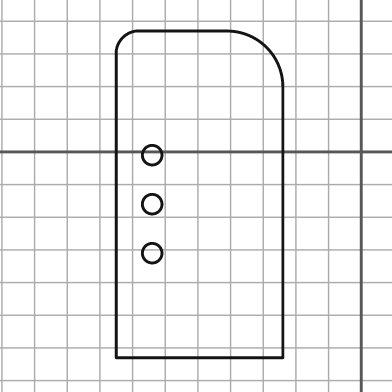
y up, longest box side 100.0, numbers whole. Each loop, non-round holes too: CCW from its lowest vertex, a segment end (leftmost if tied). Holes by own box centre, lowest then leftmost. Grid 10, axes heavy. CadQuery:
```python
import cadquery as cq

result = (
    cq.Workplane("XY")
    .moveTo(-75.0, -63.0)
    .lineTo(-24.0, -63.0)
    .lineTo(-24.0, 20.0)
    .threePointArc((-29.0, 32.0), (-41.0, 37.0))
    .lineTo(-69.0, 37.0)
    .threePointArc((-73.0, 35.0), (-75.0, 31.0))
    .close()
    .moveTo(-64.0, -31.0)
    .circle(3.0)
    .moveTo(-64.0, -16.0)
    .circle(3.0)
    .moveTo(-64.0, -1.0)
    .circle(3.0)
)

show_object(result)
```